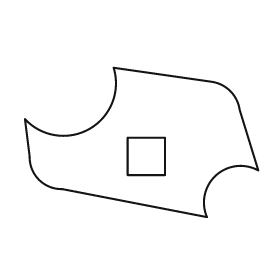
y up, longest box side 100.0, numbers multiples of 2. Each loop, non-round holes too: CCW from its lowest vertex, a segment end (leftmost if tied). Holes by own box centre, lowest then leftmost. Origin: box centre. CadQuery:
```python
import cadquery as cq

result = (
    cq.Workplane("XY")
    .moveTo(28.0, -32.0)
    .threePointArc((32.0, -14.0), (50.0, -12.0))
    .lineTo(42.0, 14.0)
    .threePointArc((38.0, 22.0), (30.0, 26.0))
    .lineTo(-12.0, 32.0)
    .threePointArc((-22.0, 6.0), (-50.0, 10.0))
    .lineTo(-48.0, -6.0)
    .threePointArc((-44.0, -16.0), (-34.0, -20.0))
    .close()
    .moveTo(-6.0, -14.0)
    .lineTo(10.0, -14.0)
    .lineTo(10.0, 2.0)
    .lineTo(-6.0, 2.0)
    .close()
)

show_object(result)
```